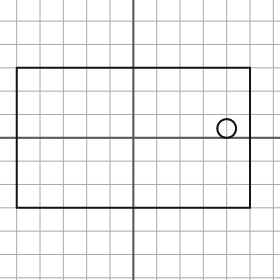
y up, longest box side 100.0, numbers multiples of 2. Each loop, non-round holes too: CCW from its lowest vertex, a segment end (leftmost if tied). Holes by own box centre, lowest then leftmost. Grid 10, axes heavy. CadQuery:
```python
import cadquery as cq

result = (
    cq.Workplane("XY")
    .moveTo(-50.0, -30.0)
    .lineTo(50.0, -30.0)
    .lineTo(50.0, 30.0)
    .lineTo(-50.0, 30.0)
    .close()
    .moveTo(40.0, 4.0)
    .circle(4.0)
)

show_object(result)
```